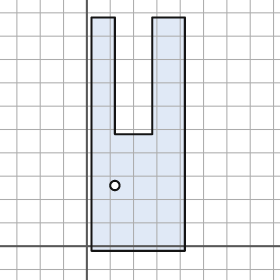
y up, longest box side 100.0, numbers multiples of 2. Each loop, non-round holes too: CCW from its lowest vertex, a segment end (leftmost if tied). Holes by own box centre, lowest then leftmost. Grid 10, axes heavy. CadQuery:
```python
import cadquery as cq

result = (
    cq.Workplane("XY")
    .moveTo(2.0, -2.0)
    .lineTo(42.0, -2.0)
    .lineTo(42.0, 98.0)
    .lineTo(28.0, 98.0)
    .lineTo(28.0, 48.0)
    .lineTo(12.0, 48.0)
    .lineTo(12.0, 98.0)
    .lineTo(2.0, 98.0)
    .close()
    .moveTo(12.0, 26.0)
    .circle(2.0)
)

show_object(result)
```